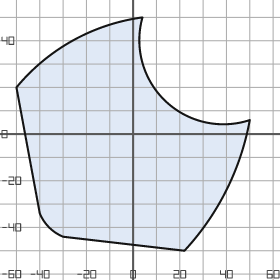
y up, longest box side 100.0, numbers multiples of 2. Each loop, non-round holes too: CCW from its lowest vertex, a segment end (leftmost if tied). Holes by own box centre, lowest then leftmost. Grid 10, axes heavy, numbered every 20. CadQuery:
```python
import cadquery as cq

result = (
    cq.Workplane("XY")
    .moveTo(22.0, -50.0)
    .threePointArc((40.0, -24.0), (50.0, 6.0))
    .threePointArc((14.0, 14.0), (4.0, 50.0))
    .threePointArc((-26.0, 40.0), (-50.0, 20.0))
    .lineTo(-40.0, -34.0)
    .threePointArc((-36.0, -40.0), (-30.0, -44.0))
    .close()
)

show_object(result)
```